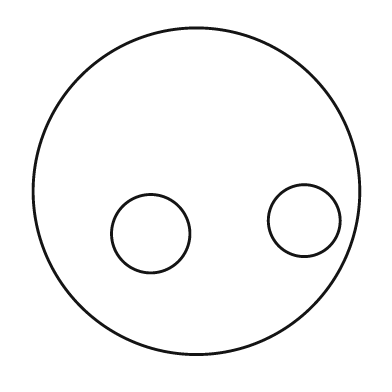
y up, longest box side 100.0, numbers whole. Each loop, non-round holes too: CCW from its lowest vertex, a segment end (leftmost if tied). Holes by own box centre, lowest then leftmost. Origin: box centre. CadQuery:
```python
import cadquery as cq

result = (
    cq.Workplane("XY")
    .moveTo(0.0, 0.0)
    .circle(50.0)
    .moveTo(-14.0, -13.0)
    .circle(12.0)
    .moveTo(33.0, -9.0)
    .circle(11.0)
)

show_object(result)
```